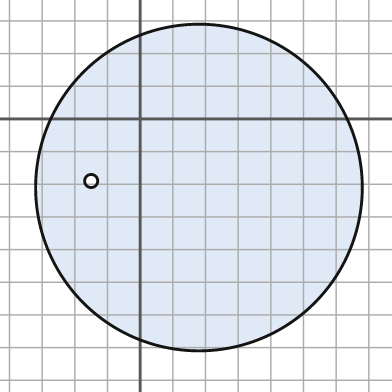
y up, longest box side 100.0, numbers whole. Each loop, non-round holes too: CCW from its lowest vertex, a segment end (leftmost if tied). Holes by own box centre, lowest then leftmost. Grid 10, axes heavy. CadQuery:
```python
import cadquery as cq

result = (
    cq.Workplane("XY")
    .moveTo(18.0, -21.0)
    .circle(50.0)
    .moveTo(-15.0, -19.0)
    .circle(2.0)
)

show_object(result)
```